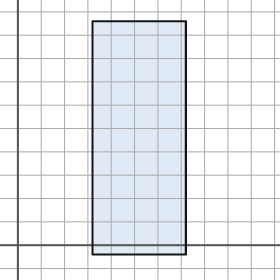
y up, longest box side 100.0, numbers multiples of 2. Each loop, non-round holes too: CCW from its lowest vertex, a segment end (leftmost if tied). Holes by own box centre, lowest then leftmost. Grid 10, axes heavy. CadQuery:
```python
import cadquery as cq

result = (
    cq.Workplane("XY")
    .moveTo(32.0, -4.0)
    .lineTo(72.0, -4.0)
    .lineTo(72.0, 96.0)
    .lineTo(32.0, 96.0)
    .close()
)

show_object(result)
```